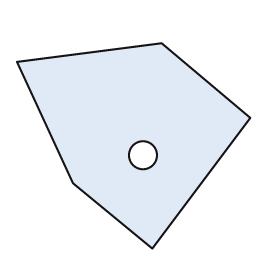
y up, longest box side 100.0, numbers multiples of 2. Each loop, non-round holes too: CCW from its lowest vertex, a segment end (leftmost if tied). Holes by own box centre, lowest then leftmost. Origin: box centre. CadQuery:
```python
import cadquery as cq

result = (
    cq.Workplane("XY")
    .moveTo(8.0, -44.0)
    .lineTo(50.0, 12.0)
    .lineTo(12.0, 44.0)
    .lineTo(-50.0, 36.0)
    .lineTo(-26.0, -16.0)
    .close()
    .moveTo(4.0, -4.0)
    .circle(6.0)
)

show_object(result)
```